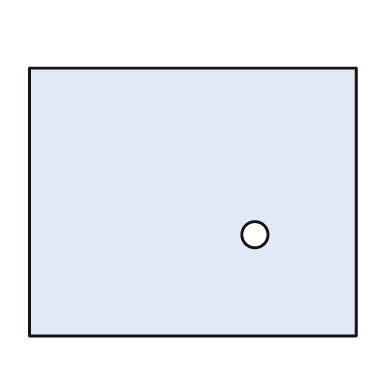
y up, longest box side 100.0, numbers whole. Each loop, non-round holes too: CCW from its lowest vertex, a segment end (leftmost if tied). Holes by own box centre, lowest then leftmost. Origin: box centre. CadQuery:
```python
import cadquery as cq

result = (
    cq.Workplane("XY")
    .moveTo(-50.0, -41.0)
    .lineTo(50.0, -41.0)
    .lineTo(50.0, 41.0)
    .lineTo(-50.0, 41.0)
    .close()
    .moveTo(19.0, -10.0)
    .circle(4.0)
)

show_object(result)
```